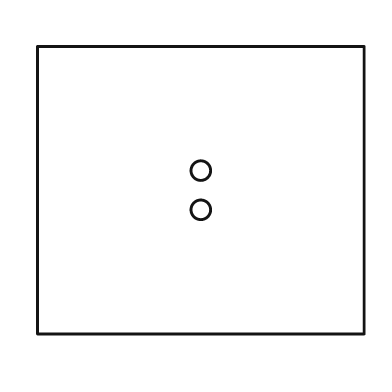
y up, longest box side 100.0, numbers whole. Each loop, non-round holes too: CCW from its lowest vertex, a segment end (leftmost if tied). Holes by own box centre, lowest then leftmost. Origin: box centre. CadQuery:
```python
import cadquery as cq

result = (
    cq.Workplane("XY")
    .moveTo(-50.0, -44.0)
    .lineTo(50.0, -44.0)
    .lineTo(50.0, 44.0)
    .lineTo(-50.0, 44.0)
    .close()
    .moveTo(0.0, -6.0)
    .circle(3.0)
    .moveTo(0.0, 6.0)
    .circle(3.0)
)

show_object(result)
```